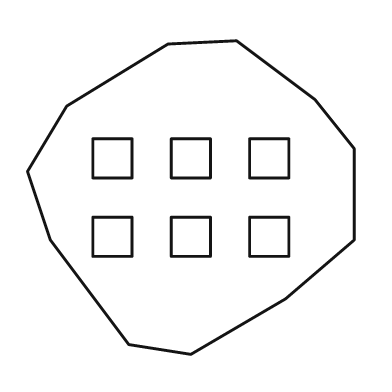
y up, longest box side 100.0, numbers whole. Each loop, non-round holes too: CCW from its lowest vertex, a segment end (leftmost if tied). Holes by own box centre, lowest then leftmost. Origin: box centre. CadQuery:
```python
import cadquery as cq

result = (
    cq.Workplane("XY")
    .moveTo(0.0, -48.0)
    .lineTo(29.0, -31.0)
    .lineTo(50.0, -13.0)
    .lineTo(50.0, 15.0)
    .lineTo(38.0, 30.0)
    .lineTo(14.0, 48.0)
    .lineTo(-7.0, 47.0)
    .lineTo(-38.0, 28.0)
    .lineTo(-50.0, 8.0)
    .lineTo(-43.0, -13.0)
    .lineTo(-19.0, -45.0)
    .close()
    .moveTo(-30.0, -18.0)
    .lineTo(-18.0, -18.0)
    .lineTo(-18.0, -6.0)
    .lineTo(-30.0, -6.0)
    .close()
    .moveTo(-6.0, -18.0)
    .lineTo(6.0, -18.0)
    .lineTo(6.0, -6.0)
    .lineTo(-6.0, -6.0)
    .close()
    .moveTo(18.0, -18.0)
    .lineTo(30.0, -18.0)
    .lineTo(30.0, -6.0)
    .lineTo(18.0, -6.0)
    .close()
    .moveTo(-30.0, 6.0)
    .lineTo(-18.0, 6.0)
    .lineTo(-18.0, 18.0)
    .lineTo(-30.0, 18.0)
    .close()
    .moveTo(-6.0, 6.0)
    .lineTo(6.0, 6.0)
    .lineTo(6.0, 18.0)
    .lineTo(-6.0, 18.0)
    .close()
    .moveTo(18.0, 6.0)
    .lineTo(30.0, 6.0)
    .lineTo(30.0, 18.0)
    .lineTo(18.0, 18.0)
    .close()
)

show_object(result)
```